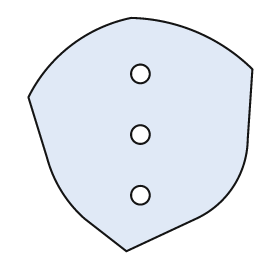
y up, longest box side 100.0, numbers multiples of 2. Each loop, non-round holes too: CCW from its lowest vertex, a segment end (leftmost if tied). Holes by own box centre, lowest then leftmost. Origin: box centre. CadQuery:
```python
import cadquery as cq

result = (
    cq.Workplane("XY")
    .moveTo(-6.0, -50.0)
    .lineTo(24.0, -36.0)
    .threePointArc((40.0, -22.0), (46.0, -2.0))
    .lineTo(48.0, 28.0)
    .threePointArc((24.0, 44.0), (-4.0, 50.0))
    .threePointArc((-30.0, 38.0), (-48.0, 16.0))
    .lineTo(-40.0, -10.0)
    .threePointArc((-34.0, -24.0), (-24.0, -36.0))
    .close()
    .moveTo(0.0, -26.0)
    .circle(4.0)
    .moveTo(0.0, 0.0)
    .circle(4.0)
    .moveTo(0.0, 26.0)
    .circle(4.0)
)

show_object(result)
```